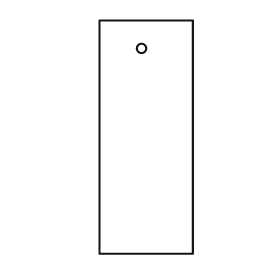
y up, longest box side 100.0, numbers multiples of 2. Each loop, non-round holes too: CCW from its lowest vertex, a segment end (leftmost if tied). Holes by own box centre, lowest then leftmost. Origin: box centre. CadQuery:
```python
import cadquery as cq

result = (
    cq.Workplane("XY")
    .moveTo(-20.0, -50.0)
    .lineTo(20.0, -50.0)
    .lineTo(20.0, 50.0)
    .lineTo(-20.0, 50.0)
    .close()
    .moveTo(-2.0, 38.0)
    .circle(2.0)
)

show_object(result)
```